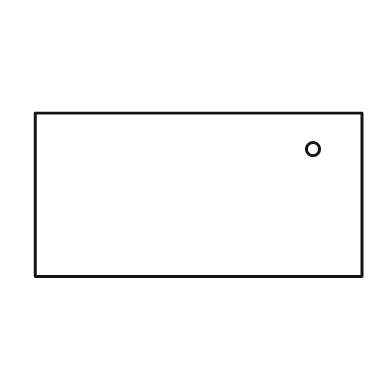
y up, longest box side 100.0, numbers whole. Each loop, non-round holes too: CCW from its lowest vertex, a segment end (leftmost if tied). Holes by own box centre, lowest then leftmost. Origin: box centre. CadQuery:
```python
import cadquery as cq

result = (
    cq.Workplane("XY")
    .moveTo(-50.0, -25.0)
    .lineTo(50.0, -25.0)
    .lineTo(50.0, 25.0)
    .lineTo(-50.0, 25.0)
    .close()
    .moveTo(35.0, 14.0)
    .circle(2.0)
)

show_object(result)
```